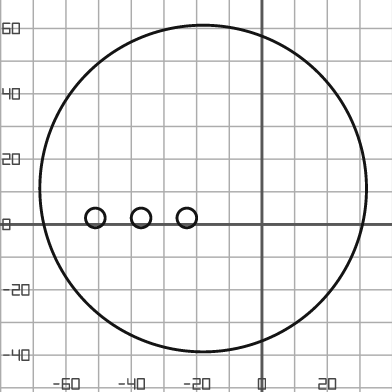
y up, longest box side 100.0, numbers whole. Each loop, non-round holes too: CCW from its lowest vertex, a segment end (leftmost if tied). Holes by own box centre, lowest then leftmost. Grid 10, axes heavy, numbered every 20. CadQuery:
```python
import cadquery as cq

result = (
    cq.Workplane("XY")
    .moveTo(-18.0, 11.0)
    .circle(50.0)
    .moveTo(-51.0, 2.0)
    .circle(3.0)
    .moveTo(-37.0, 2.0)
    .circle(3.0)
    .moveTo(-23.0, 2.0)
    .circle(3.0)
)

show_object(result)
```